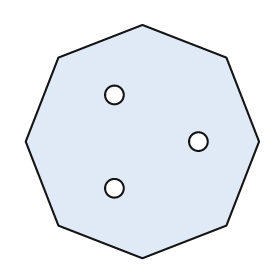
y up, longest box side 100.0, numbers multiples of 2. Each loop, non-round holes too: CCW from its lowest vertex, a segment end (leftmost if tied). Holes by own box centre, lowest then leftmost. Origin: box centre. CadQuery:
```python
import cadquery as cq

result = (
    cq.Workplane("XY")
    .moveTo(0.0, -50.0)
    .lineTo(36.0, -36.0)
    .lineTo(50.0, 0.0)
    .lineTo(36.0, 36.0)
    .lineTo(0.0, 50.0)
    .lineTo(-36.0, 36.0)
    .lineTo(-50.0, 0.0)
    .lineTo(-36.0, -36.0)
    .close()
    .moveTo(-12.0, -20.0)
    .circle(4.0)
    .moveTo(24.0, 0.0)
    .circle(4.0)
    .moveTo(-12.0, 20.0)
    .circle(4.0)
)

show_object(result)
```